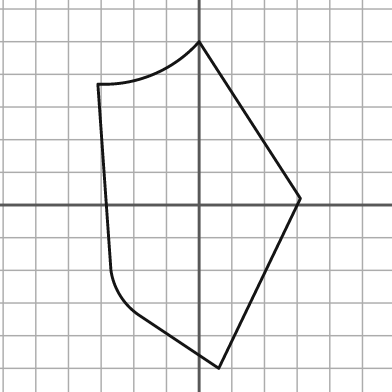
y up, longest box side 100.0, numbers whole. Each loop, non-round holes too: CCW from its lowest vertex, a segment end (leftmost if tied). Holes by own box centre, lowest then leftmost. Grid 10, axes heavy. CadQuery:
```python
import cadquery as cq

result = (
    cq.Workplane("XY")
    .moveTo(6.0, -50.0)
    .lineTo(31.0, 2.0)
    .lineTo(0.0, 50.0)
    .threePointArc((-14.0, 40.0), (-31.0, 37.0))
    .lineTo(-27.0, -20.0)
    .threePointArc((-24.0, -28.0), (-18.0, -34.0))
    .close()
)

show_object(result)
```